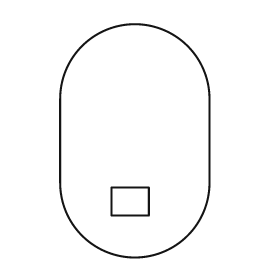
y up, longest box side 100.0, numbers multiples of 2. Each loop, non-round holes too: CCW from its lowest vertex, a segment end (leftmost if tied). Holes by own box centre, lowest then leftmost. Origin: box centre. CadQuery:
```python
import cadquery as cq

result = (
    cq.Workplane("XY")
    .moveTo(-32.0, -18.0)
    .threePointArc((0.0, -50.0), (32.0, -18.0))
    .lineTo(32.0, 18.0)
    .threePointArc((0.0, 50.0), (-32.0, 18.0))
    .close()
    .moveTo(-10.0, -32.0)
    .lineTo(6.0, -32.0)
    .lineTo(6.0, -20.0)
    .lineTo(-10.0, -20.0)
    .close()
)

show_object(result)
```